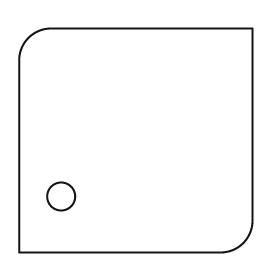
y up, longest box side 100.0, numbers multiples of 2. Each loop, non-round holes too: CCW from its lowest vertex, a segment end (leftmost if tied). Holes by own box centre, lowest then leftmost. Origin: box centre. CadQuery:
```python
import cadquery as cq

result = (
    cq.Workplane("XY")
    .moveTo(-50.0, -48.0)
    .lineTo(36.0, -48.0)
    .threePointArc((46.0, -44.0), (50.0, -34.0))
    .lineTo(50.0, 48.0)
    .lineTo(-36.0, 48.0)
    .threePointArc((-46.0, 44.0), (-50.0, 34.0))
    .close()
    .moveTo(-32.0, -24.0)
    .circle(6.0)
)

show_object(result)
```